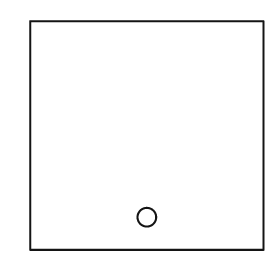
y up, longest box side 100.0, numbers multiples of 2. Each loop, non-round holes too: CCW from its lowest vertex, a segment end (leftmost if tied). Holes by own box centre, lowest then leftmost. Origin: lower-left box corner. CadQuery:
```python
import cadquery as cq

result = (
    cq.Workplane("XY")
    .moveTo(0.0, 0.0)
    .lineTo(100.0, 0.0)
    .lineTo(100.0, 98.0)
    .lineTo(0.0, 98.0)
    .close()
    .moveTo(50.0, 14.0)
    .circle(4.0)
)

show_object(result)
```